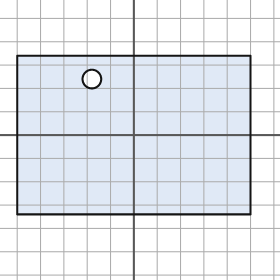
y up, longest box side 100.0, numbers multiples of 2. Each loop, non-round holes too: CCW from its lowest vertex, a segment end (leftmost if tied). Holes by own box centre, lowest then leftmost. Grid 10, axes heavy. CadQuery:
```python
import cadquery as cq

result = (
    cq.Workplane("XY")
    .moveTo(-50.0, -34.0)
    .lineTo(50.0, -34.0)
    .lineTo(50.0, 34.0)
    .lineTo(-50.0, 34.0)
    .close()
    .moveTo(-18.0, 24.0)
    .circle(4.0)
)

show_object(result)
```